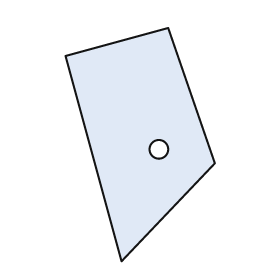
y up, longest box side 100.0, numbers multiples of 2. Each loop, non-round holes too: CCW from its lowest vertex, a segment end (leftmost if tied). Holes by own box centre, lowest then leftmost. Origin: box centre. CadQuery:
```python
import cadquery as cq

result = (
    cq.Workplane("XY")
    .moveTo(-8.0, -50.0)
    .lineTo(32.0, -8.0)
    .lineTo(12.0, 50.0)
    .lineTo(-32.0, 38.0)
    .close()
    .moveTo(8.0, -2.0)
    .circle(4.0)
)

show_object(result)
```